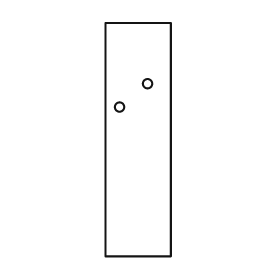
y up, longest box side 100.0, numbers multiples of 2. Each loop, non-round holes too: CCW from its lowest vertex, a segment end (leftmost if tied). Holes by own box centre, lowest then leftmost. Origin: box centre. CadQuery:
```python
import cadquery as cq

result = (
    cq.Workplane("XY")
    .moveTo(-14.0, -50.0)
    .lineTo(14.0, -50.0)
    .lineTo(14.0, 50.0)
    .lineTo(-14.0, 50.0)
    .close()
    .moveTo(-8.0, 14.0)
    .circle(2.0)
    .moveTo(4.0, 24.0)
    .circle(2.0)
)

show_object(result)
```